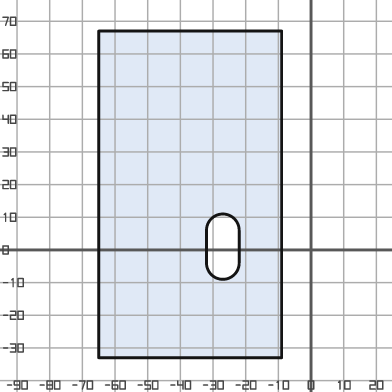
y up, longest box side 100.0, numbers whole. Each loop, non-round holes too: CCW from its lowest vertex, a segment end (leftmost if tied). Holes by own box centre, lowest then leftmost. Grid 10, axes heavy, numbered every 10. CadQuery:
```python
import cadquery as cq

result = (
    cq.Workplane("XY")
    .moveTo(-65.0, -33.0)
    .lineTo(-9.0, -33.0)
    .lineTo(-9.0, 67.0)
    .lineTo(-65.0, 67.0)
    .close()
    .moveTo(-32.0, -4.0)
    .threePointArc((-27.0, -9.0), (-22.0, -4.0))
    .lineTo(-22.0, 6.0)
    .threePointArc((-27.0, 11.0), (-32.0, 6.0))
    .close()
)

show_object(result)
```